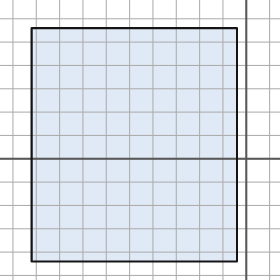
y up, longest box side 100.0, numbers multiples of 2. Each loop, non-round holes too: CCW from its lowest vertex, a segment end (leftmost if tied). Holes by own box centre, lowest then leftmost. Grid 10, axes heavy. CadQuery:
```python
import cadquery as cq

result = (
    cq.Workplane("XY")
    .moveTo(-92.0, -44.0)
    .lineTo(-4.0, -44.0)
    .lineTo(-4.0, 56.0)
    .lineTo(-92.0, 56.0)
    .close()
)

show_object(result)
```